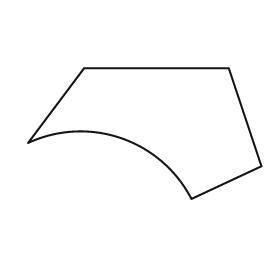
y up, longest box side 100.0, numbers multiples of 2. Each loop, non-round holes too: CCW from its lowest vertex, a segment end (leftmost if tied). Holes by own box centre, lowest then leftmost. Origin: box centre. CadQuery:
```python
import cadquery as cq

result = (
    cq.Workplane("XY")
    .moveTo(20.0, -28.0)
    .lineTo(50.0, -14.0)
    .lineTo(36.0, 28.0)
    .lineTo(-26.0, 28.0)
    .lineTo(-50.0, -4.0)
    .threePointArc((-10.0, -2.0), (20.0, -28.0))
    .close()
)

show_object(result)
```